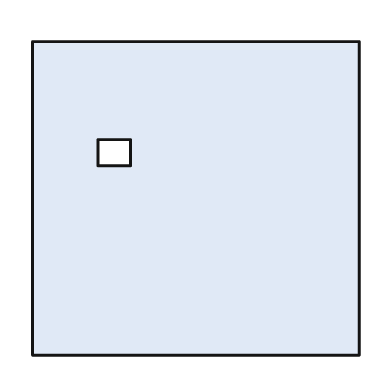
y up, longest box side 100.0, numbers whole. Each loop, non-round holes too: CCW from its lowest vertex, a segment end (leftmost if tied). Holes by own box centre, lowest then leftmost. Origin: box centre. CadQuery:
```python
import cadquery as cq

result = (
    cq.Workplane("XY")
    .moveTo(-50.0, -48.0)
    .lineTo(50.0, -48.0)
    .lineTo(50.0, 48.0)
    .lineTo(-50.0, 48.0)
    .close()
    .moveTo(-30.0, 10.0)
    .lineTo(-20.0, 10.0)
    .lineTo(-20.0, 18.0)
    .lineTo(-30.0, 18.0)
    .close()
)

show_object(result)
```